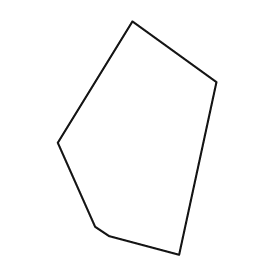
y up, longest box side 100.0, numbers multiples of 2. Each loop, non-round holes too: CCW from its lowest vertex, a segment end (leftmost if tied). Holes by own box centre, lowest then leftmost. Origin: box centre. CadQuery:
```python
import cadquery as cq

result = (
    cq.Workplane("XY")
    .moveTo(18.0, -50.0)
    .lineTo(34.0, 24.0)
    .lineTo(-2.0, 50.0)
    .lineTo(-34.0, -2.0)
    .lineTo(-18.0, -38.0)
    .lineTo(-12.0, -42.0)
    .close()
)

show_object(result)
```